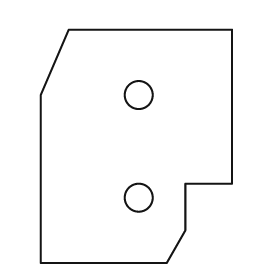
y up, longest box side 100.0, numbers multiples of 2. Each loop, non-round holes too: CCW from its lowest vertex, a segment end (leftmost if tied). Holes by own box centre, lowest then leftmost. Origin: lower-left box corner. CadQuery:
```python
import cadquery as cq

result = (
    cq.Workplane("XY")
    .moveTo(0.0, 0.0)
    .lineTo(54.0, 0.0)
    .lineTo(62.0, 14.0)
    .lineTo(62.0, 34.0)
    .lineTo(82.0, 34.0)
    .lineTo(82.0, 100.0)
    .lineTo(12.0, 100.0)
    .lineTo(0.0, 72.0)
    .close()
    .moveTo(42.0, 28.0)
    .circle(6.0)
    .moveTo(42.0, 72.0)
    .circle(6.0)
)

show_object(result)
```